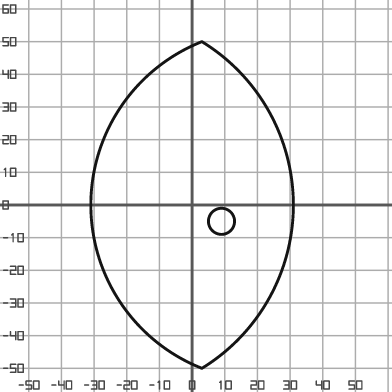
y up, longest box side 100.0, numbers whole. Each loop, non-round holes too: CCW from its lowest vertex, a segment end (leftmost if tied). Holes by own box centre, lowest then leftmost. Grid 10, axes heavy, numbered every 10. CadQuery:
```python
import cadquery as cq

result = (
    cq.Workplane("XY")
    .moveTo(3.0, -50.0)
    .threePointArc((31.0, 0.0), (3.0, 50.0))
    .threePointArc((-31.0, 0.0), (3.0, -50.0))
    .close()
    .moveTo(9.0, -5.0)
    .circle(4.0)
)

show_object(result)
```